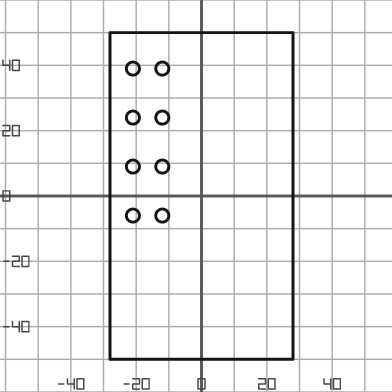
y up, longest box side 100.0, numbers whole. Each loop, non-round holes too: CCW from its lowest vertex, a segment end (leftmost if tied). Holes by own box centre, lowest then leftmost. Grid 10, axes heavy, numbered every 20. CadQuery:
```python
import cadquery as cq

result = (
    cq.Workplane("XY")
    .moveTo(-28.0, -50.0)
    .lineTo(28.0, -50.0)
    .lineTo(28.0, 50.0)
    .lineTo(-28.0, 50.0)
    .close()
    .moveTo(-21.0, -6.0)
    .circle(2.0)
    .moveTo(-12.0, -6.0)
    .circle(2.0)
    .moveTo(-21.0, 9.0)
    .circle(2.0)
    .moveTo(-12.0, 9.0)
    .circle(2.0)
    .moveTo(-21.0, 24.0)
    .circle(2.0)
    .moveTo(-12.0, 24.0)
    .circle(2.0)
    .moveTo(-21.0, 39.0)
    .circle(2.0)
    .moveTo(-12.0, 39.0)
    .circle(2.0)
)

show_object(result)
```